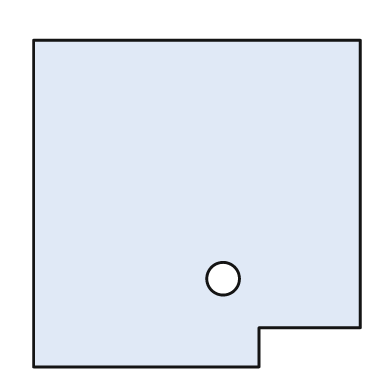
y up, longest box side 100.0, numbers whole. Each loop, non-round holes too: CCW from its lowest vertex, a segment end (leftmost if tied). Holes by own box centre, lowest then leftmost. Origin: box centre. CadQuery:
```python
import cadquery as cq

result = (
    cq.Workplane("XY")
    .moveTo(-50.0, -50.0)
    .lineTo(19.0, -50.0)
    .lineTo(19.0, -38.0)
    .lineTo(50.0, -38.0)
    .lineTo(50.0, 50.0)
    .lineTo(-50.0, 50.0)
    .close()
    .moveTo(8.0, -23.0)
    .circle(5.0)
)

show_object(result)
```